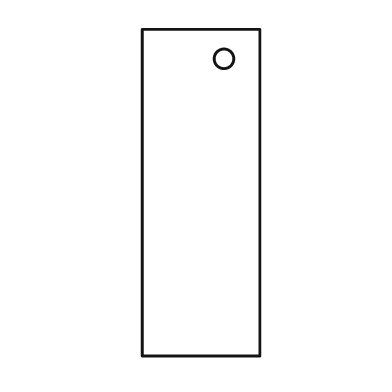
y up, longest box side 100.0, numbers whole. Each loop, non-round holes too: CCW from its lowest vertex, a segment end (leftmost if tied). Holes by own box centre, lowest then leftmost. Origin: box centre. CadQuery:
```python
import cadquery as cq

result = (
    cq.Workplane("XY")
    .moveTo(-18.0, -50.0)
    .lineTo(18.0, -50.0)
    .lineTo(18.0, 50.0)
    .lineTo(-18.0, 50.0)
    .close()
    .moveTo(7.0, 41.0)
    .circle(3.0)
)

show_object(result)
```